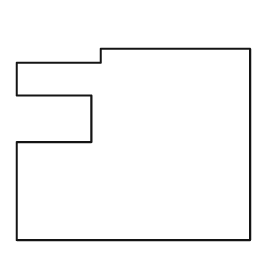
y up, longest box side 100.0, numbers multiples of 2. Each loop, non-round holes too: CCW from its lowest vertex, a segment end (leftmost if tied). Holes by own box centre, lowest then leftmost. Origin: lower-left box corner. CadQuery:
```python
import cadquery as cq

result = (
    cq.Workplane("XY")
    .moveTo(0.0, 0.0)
    .lineTo(100.0, 0.0)
    .lineTo(100.0, 82.0)
    .lineTo(36.0, 82.0)
    .lineTo(36.0, 76.0)
    .lineTo(0.0, 76.0)
    .lineTo(0.0, 62.0)
    .lineTo(32.0, 62.0)
    .lineTo(32.0, 42.0)
    .lineTo(0.0, 42.0)
    .close()
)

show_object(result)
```